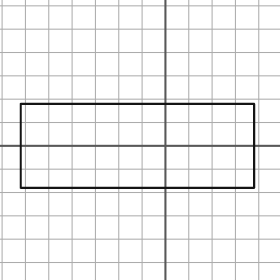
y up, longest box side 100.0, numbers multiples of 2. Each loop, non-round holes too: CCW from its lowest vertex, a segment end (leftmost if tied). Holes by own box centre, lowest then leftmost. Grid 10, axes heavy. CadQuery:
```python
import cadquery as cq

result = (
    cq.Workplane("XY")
    .moveTo(-62.0, -18.0)
    .lineTo(38.0, -18.0)
    .lineTo(38.0, 18.0)
    .lineTo(-62.0, 18.0)
    .close()
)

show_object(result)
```